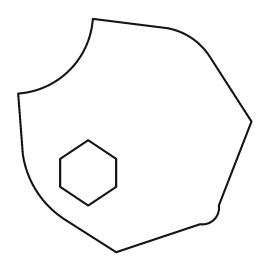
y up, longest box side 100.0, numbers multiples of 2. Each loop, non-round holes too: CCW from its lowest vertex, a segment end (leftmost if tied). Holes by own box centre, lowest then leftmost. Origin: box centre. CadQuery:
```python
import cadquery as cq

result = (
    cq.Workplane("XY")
    .moveTo(-8.0, -50.0)
    .lineTo(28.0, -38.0)
    .threePointArc((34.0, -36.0), (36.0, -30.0))
    .lineTo(50.0, 6.0)
    .lineTo(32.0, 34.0)
    .threePointArc((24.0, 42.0), (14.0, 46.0))
    .lineTo(-18.0, 50.0)
    .threePointArc((-28.0, 28.0), (-50.0, 18.0))
    .lineTo(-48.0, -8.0)
    .threePointArc((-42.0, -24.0), (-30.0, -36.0))
    .close()
    .moveTo(-20.0, -30.0)
    .lineTo(-8.0, -22.0)
    .lineTo(-8.0, -10.0)
    .lineTo(-20.0, -2.0)
    .lineTo(-32.0, -10.0)
    .lineTo(-32.0, -22.0)
    .close()
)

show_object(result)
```